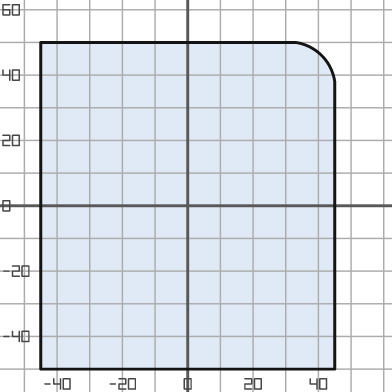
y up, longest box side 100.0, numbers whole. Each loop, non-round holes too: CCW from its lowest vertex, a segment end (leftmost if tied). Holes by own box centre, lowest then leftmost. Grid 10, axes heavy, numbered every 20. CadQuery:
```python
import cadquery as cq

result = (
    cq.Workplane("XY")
    .moveTo(-45.0, -50.0)
    .lineTo(45.0, -50.0)
    .lineTo(45.0, 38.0)
    .threePointArc((41.0, 46.0), (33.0, 50.0))
    .lineTo(-45.0, 50.0)
    .close()
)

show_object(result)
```